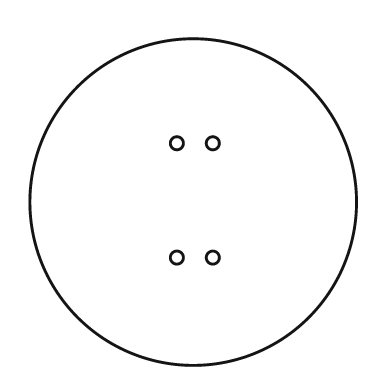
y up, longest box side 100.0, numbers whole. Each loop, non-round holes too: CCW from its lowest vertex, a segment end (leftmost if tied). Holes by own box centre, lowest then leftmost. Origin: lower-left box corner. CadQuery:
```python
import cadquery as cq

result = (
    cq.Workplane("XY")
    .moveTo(50.0, 50.0)
    .circle(50.0)
    .moveTo(45.0, 33.0)
    .circle(2.0)
    .moveTo(56.0, 33.0)
    .circle(2.0)
    .moveTo(45.0, 68.0)
    .circle(2.0)
    .moveTo(56.0, 68.0)
    .circle(2.0)
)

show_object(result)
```